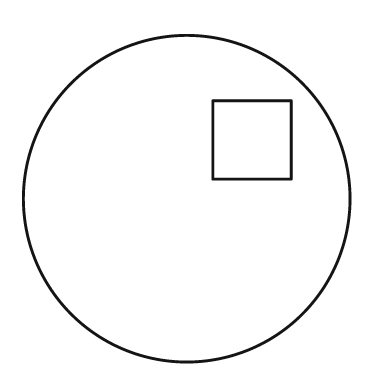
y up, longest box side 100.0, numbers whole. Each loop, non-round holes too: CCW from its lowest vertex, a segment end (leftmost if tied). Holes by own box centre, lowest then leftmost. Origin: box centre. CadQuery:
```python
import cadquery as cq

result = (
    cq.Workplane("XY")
    .moveTo(0.0, 0.0)
    .circle(50.0)
    .moveTo(8.0, 6.0)
    .lineTo(32.0, 6.0)
    .lineTo(32.0, 30.0)
    .lineTo(8.0, 30.0)
    .close()
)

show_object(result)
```